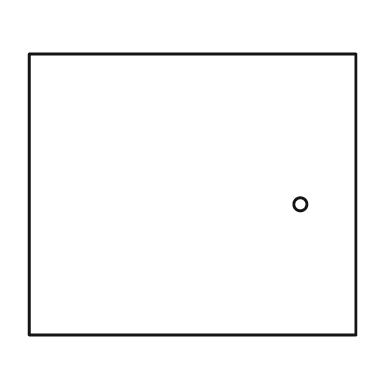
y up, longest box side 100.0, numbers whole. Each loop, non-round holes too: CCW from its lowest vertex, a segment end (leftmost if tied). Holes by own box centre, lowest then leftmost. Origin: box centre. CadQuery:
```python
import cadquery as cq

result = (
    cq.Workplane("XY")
    .moveTo(-50.0, -43.0)
    .lineTo(50.0, -43.0)
    .lineTo(50.0, 43.0)
    .lineTo(-50.0, 43.0)
    .close()
    .moveTo(33.0, -3.0)
    .circle(2.0)
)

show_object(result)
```